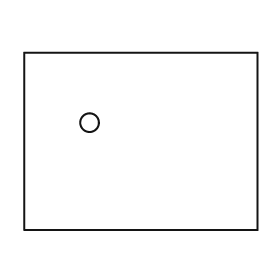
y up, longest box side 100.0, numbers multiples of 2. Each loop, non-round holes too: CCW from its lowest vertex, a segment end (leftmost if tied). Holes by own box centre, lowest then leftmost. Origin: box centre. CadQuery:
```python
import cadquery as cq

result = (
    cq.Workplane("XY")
    .moveTo(-50.0, -38.0)
    .lineTo(50.0, -38.0)
    .lineTo(50.0, 38.0)
    .lineTo(-50.0, 38.0)
    .close()
    .moveTo(-22.0, 8.0)
    .circle(4.0)
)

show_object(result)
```